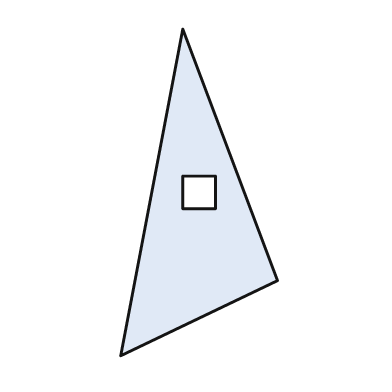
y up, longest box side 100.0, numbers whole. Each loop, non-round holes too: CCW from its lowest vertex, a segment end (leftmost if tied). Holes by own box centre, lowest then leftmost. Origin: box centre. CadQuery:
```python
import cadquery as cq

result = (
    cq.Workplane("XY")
    .moveTo(-24.0, -50.0)
    .lineTo(24.0, -27.0)
    .lineTo(-5.0, 50.0)
    .close()
    .moveTo(-5.0, -5.0)
    .lineTo(5.0, -5.0)
    .lineTo(5.0, 5.0)
    .lineTo(-5.0, 5.0)
    .close()
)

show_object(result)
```